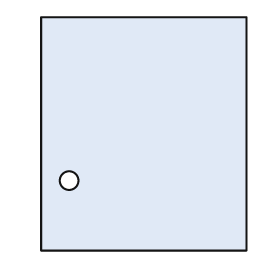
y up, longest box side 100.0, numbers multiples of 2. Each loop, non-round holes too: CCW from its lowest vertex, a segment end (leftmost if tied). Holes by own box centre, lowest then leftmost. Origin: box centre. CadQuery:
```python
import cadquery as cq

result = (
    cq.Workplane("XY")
    .moveTo(-44.0, -50.0)
    .lineTo(44.0, -50.0)
    .lineTo(44.0, 50.0)
    .lineTo(-44.0, 50.0)
    .close()
    .moveTo(-32.0, -20.0)
    .circle(4.0)
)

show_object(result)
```